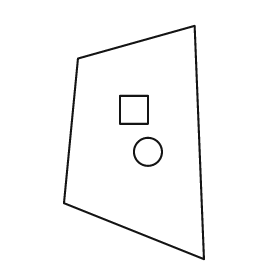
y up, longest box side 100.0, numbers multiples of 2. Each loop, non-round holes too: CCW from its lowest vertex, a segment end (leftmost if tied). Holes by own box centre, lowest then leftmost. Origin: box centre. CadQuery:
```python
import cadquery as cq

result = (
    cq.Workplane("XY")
    .moveTo(30.0, -50.0)
    .lineTo(26.0, 50.0)
    .lineTo(-24.0, 36.0)
    .lineTo(-30.0, -26.0)
    .close()
    .moveTo(6.0, -4.0)
    .circle(6.0)
    .moveTo(-6.0, 8.0)
    .lineTo(6.0, 8.0)
    .lineTo(6.0, 20.0)
    .lineTo(-6.0, 20.0)
    .close()
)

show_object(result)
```